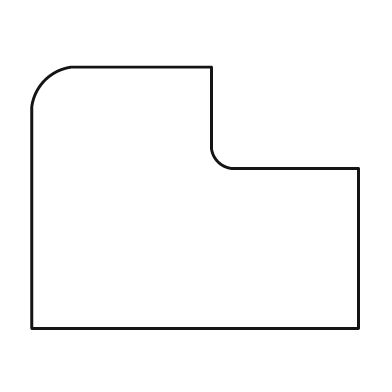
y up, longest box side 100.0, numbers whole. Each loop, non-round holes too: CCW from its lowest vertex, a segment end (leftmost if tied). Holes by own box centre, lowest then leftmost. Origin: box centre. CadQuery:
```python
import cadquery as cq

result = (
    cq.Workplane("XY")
    .moveTo(-50.0, -40.0)
    .lineTo(50.0, -40.0)
    .lineTo(50.0, 9.0)
    .lineTo(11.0, 9.0)
    .threePointArc((7.0, 11.0), (5.0, 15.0))
    .lineTo(5.0, 40.0)
    .lineTo(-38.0, 40.0)
    .threePointArc((-46.0, 36.0), (-50.0, 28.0))
    .close()
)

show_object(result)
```